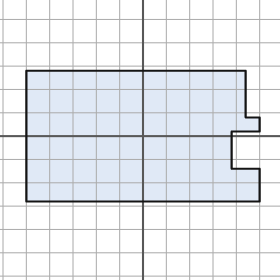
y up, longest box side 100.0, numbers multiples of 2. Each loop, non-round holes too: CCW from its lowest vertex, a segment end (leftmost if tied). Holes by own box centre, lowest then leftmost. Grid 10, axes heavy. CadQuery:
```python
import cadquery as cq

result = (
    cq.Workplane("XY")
    .moveTo(-50.0, -28.0)
    .lineTo(50.0, -28.0)
    .lineTo(50.0, -14.0)
    .lineTo(38.0, -14.0)
    .lineTo(38.0, 2.0)
    .lineTo(50.0, 2.0)
    .lineTo(50.0, 8.0)
    .lineTo(44.0, 8.0)
    .lineTo(44.0, 28.0)
    .lineTo(-50.0, 28.0)
    .close()
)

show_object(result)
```